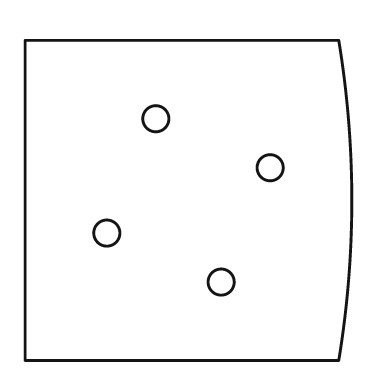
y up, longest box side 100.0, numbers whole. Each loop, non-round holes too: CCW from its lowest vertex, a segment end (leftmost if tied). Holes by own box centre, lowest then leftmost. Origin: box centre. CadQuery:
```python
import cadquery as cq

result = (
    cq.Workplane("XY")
    .moveTo(-50.0, -49.0)
    .lineTo(46.0, -49.0)
    .threePointArc((50.0, 0.0), (46.0, 49.0))
    .lineTo(-50.0, 49.0)
    .close()
    .moveTo(10.0, -25.0)
    .circle(4.0)
    .moveTo(-25.0, -10.0)
    .circle(4.0)
    .moveTo(25.0, 10.0)
    .circle(4.0)
    .moveTo(-10.0, 25.0)
    .circle(4.0)
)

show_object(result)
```